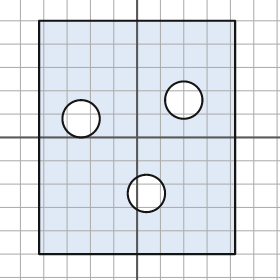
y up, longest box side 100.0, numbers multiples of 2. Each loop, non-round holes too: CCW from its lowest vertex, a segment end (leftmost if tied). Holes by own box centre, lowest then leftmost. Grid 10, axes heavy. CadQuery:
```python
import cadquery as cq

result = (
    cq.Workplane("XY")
    .moveTo(-42.0, -50.0)
    .lineTo(42.0, -50.0)
    .lineTo(42.0, 50.0)
    .lineTo(-42.0, 50.0)
    .close()
    .moveTo(4.0, -24.0)
    .circle(8.0)
    .moveTo(-24.0, 8.0)
    .circle(8.0)
    .moveTo(20.0, 16.0)
    .circle(8.0)
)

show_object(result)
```